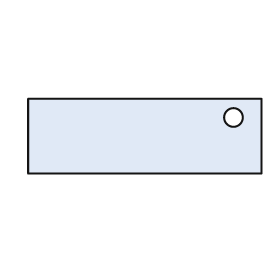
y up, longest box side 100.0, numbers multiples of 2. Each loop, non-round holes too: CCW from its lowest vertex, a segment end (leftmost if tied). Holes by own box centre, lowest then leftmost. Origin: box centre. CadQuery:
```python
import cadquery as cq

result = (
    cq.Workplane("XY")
    .moveTo(-50.0, -16.0)
    .lineTo(50.0, -16.0)
    .lineTo(50.0, 16.0)
    .lineTo(-50.0, 16.0)
    .close()
    .moveTo(38.0, 8.0)
    .circle(4.0)
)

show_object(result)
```